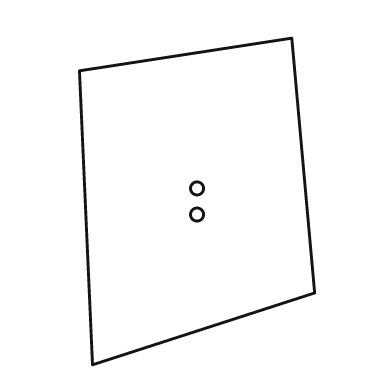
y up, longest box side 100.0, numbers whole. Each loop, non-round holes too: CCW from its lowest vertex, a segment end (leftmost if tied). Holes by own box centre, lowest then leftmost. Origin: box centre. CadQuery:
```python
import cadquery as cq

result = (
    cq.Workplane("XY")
    .moveTo(-32.0, -50.0)
    .lineTo(36.0, -28.0)
    .lineTo(29.0, 50.0)
    .lineTo(-36.0, 40.0)
    .close()
    .moveTo(0.0, -4.0)
    .circle(2.0)
    .moveTo(0.0, 4.0)
    .circle(2.0)
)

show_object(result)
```